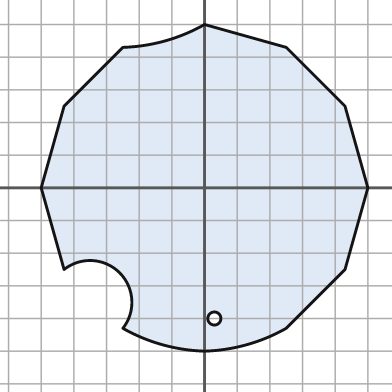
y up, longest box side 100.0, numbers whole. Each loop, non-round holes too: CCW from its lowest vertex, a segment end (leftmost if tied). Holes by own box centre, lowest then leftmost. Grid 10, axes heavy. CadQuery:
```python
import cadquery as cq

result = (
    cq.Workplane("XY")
    .moveTo(0.0, -50.0)
    .threePointArc((13.0, -48.0), (25.0, -43.0))
    .lineTo(43.0, -25.0)
    .lineTo(50.0, 0.0)
    .lineTo(43.0, 25.0)
    .lineTo(25.0, 43.0)
    .lineTo(0.0, 50.0)
    .threePointArc((-12.0, 45.0), (-25.0, 43.0))
    .lineTo(-43.0, 25.0)
    .lineTo(-50.0, 0.0)
    .lineTo(-43.0, -25.0)
    .threePointArc((-26.0, -26.0), (-25.0, -43.0))
    .threePointArc((-13.0, -48.0), (0.0, -50.0))
    .close()
    .moveTo(3.0, -40.0)
    .circle(2.0)
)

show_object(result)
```